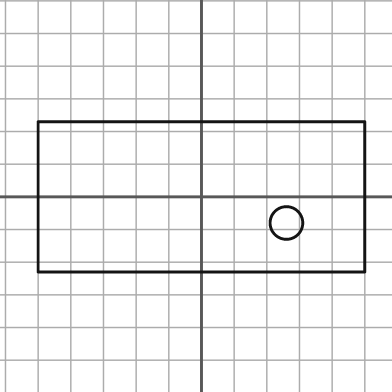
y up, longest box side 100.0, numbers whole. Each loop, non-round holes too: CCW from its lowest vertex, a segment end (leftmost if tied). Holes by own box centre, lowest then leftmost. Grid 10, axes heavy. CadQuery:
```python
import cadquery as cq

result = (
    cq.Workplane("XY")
    .moveTo(-50.0, -23.0)
    .lineTo(50.0, -23.0)
    .lineTo(50.0, 23.0)
    .lineTo(-50.0, 23.0)
    .close()
    .moveTo(26.0, -8.0)
    .circle(5.0)
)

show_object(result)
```